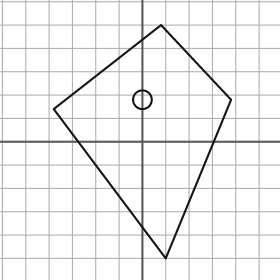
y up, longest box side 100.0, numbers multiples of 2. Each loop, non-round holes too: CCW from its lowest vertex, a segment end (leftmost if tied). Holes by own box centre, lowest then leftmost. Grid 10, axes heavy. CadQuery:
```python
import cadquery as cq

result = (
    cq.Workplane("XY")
    .moveTo(10.0, -50.0)
    .lineTo(38.0, 18.0)
    .lineTo(8.0, 50.0)
    .lineTo(-38.0, 14.0)
    .close()
    .moveTo(0.0, 18.0)
    .circle(4.0)
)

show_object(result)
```